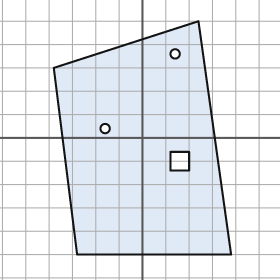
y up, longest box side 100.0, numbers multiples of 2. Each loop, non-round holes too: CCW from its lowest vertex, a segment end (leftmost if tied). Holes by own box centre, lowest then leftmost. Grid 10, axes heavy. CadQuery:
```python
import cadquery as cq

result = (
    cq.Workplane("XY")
    .moveTo(-28.0, -50.0)
    .lineTo(38.0, -50.0)
    .lineTo(24.0, 50.0)
    .lineTo(-38.0, 30.0)
    .close()
    .moveTo(12.0, -14.0)
    .lineTo(20.0, -14.0)
    .lineTo(20.0, -6.0)
    .lineTo(12.0, -6.0)
    .close()
    .moveTo(-16.0, 4.0)
    .circle(2.0)
    .moveTo(14.0, 36.0)
    .circle(2.0)
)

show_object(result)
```